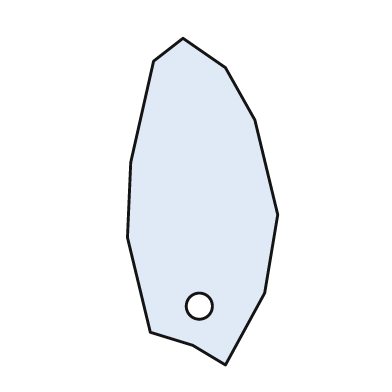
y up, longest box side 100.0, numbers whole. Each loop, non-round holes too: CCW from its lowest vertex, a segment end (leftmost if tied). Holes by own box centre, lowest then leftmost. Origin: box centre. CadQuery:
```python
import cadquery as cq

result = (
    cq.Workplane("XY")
    .moveTo(7.0, -50.0)
    .lineTo(19.0, -28.0)
    .lineTo(23.0, -4.0)
    .lineTo(16.0, 25.0)
    .lineTo(7.0, 41.0)
    .lineTo(-6.0, 50.0)
    .lineTo(-15.0, 43.0)
    .lineTo(-22.0, 12.0)
    .lineTo(-23.0, -11.0)
    .lineTo(-16.0, -40.0)
    .lineTo(-3.0, -44.0)
    .close()
    .moveTo(-1.0, -32.0)
    .circle(4.0)
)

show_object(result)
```